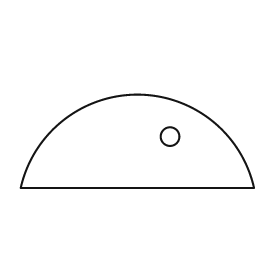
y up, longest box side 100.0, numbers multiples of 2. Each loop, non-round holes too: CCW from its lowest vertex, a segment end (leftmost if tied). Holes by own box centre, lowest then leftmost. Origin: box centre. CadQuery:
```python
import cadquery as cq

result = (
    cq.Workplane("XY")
    .moveTo(-50.0, -20.0)
    .lineTo(50.0, -20.0)
    .threePointArc((0.0, 20.0), (-50.0, -20.0))
    .close()
    .moveTo(14.0, 2.0)
    .circle(4.0)
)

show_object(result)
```